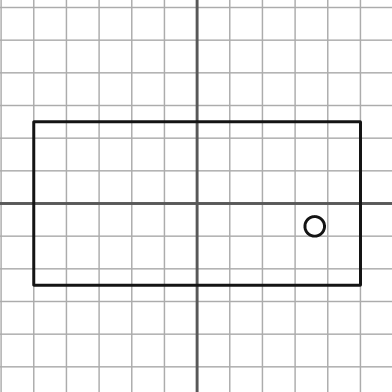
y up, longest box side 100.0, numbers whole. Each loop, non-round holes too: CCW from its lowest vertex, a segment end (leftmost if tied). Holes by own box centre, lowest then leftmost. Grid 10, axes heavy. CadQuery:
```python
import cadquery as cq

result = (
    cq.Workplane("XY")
    .moveTo(-50.0, -25.0)
    .lineTo(50.0, -25.0)
    .lineTo(50.0, 25.0)
    .lineTo(-50.0, 25.0)
    .close()
    .moveTo(36.0, -7.0)
    .circle(3.0)
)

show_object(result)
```